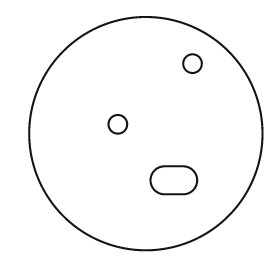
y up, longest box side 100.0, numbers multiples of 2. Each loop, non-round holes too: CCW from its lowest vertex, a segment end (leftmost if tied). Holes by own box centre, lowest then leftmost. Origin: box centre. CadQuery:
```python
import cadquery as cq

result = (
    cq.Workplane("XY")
    .moveTo(0.0, 0.0)
    .circle(50.0)
    .moveTo(8.0, -26.0)
    .lineTo(16.0, -26.0)
    .threePointArc((22.0, -20.0), (16.0, -14.0))
    .lineTo(8.0, -14.0)
    .threePointArc((2.0, -20.0), (8.0, -26.0))
    .close()
    .moveTo(-12.0, 4.0)
    .circle(4.0)
    .moveTo(20.0, 30.0)
    .circle(4.0)
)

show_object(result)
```